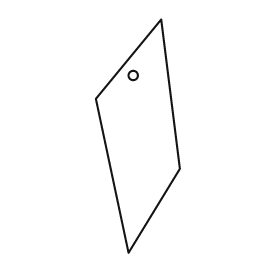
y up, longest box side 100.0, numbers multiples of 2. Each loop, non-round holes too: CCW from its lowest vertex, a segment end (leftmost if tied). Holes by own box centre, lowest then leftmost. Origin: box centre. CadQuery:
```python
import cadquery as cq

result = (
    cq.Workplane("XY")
    .moveTo(-4.0, -50.0)
    .lineTo(18.0, -14.0)
    .lineTo(10.0, 50.0)
    .lineTo(-18.0, 16.0)
    .close()
    .moveTo(-2.0, 26.0)
    .circle(2.0)
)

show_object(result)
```